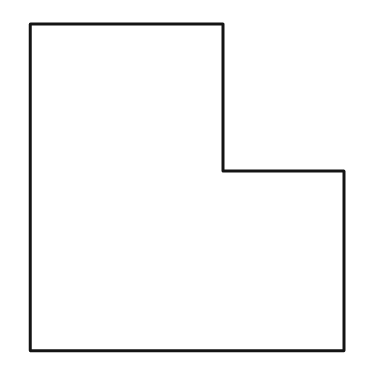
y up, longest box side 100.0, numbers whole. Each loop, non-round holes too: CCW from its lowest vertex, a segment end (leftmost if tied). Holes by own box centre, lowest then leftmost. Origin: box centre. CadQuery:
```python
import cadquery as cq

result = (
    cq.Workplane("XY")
    .moveTo(-48.0, -50.0)
    .lineTo(48.0, -50.0)
    .lineTo(48.0, 5.0)
    .lineTo(11.0, 5.0)
    .lineTo(11.0, 50.0)
    .lineTo(-48.0, 50.0)
    .close()
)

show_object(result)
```